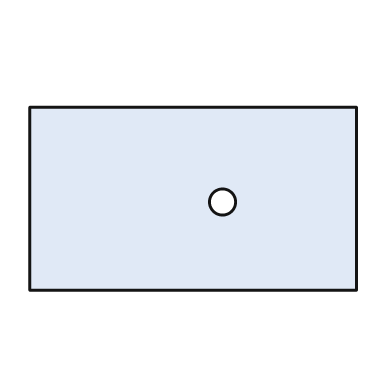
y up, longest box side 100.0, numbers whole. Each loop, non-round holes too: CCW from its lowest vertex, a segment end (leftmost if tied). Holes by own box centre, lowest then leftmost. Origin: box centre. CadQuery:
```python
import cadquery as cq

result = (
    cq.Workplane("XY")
    .moveTo(-50.0, -28.0)
    .lineTo(50.0, -28.0)
    .lineTo(50.0, 28.0)
    .lineTo(-50.0, 28.0)
    .close()
    .moveTo(9.0, -1.0)
    .circle(4.0)
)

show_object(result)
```